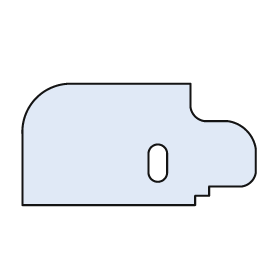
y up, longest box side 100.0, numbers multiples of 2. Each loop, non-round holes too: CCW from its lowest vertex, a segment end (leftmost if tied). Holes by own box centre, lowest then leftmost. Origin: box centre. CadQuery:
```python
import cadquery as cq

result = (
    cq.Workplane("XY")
    .moveTo(-50.0, -26.0)
    .lineTo(24.0, -26.0)
    .lineTo(24.0, -22.0)
    .lineTo(30.0, -22.0)
    .lineTo(30.0, -18.0)
    .lineTo(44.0, -18.0)
    .threePointArc((48.0, -16.0), (50.0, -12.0))
    .lineTo(50.0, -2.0)
    .threePointArc((46.0, 6.0), (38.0, 10.0))
    .lineTo(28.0, 10.0)
    .threePointArc((24.0, 12.0), (22.0, 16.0))
    .lineTo(22.0, 26.0)
    .lineTo(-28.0, 26.0)
    .threePointArc((-44.0, 20.0), (-50.0, 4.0))
    .close()
    .moveTo(4.0, -12.0)
    .threePointArc((8.0, -16.0), (12.0, -12.0))
    .lineTo(12.0, -4.0)
    .threePointArc((8.0, 0.0), (4.0, -4.0))
    .close()
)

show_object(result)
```